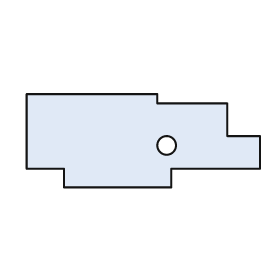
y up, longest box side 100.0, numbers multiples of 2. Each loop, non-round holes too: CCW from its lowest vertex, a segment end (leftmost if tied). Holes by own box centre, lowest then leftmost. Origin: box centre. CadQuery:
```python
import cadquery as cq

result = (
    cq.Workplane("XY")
    .moveTo(-34.0, -20.0)
    .lineTo(12.0, -20.0)
    .lineTo(12.0, -12.0)
    .lineTo(50.0, -12.0)
    .lineTo(50.0, 2.0)
    .lineTo(36.0, 2.0)
    .lineTo(36.0, 16.0)
    .lineTo(6.0, 16.0)
    .lineTo(6.0, 20.0)
    .lineTo(-50.0, 20.0)
    .lineTo(-50.0, -12.0)
    .lineTo(-34.0, -12.0)
    .close()
    .moveTo(10.0, -2.0)
    .circle(4.0)
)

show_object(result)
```